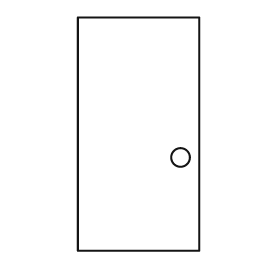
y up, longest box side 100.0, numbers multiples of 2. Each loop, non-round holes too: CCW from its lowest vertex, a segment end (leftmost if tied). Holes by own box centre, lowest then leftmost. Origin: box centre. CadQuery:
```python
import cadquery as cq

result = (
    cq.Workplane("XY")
    .moveTo(-26.0, -50.0)
    .lineTo(26.0, -50.0)
    .lineTo(26.0, 50.0)
    .lineTo(-26.0, 50.0)
    .close()
    .moveTo(18.0, -10.0)
    .circle(4.0)
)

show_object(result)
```